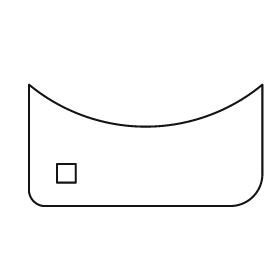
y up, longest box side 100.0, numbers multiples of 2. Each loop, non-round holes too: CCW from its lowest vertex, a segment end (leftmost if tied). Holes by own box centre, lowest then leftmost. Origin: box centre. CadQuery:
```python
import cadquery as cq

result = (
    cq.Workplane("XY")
    .moveTo(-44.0, -26.0)
    .lineTo(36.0, -26.0)
    .threePointArc((46.0, -22.0), (50.0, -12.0))
    .lineTo(50.0, 26.0)
    .threePointArc((0.0, 8.0), (-50.0, 26.0))
    .lineTo(-50.0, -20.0)
    .threePointArc((-48.0, -24.0), (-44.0, -26.0))
    .close()
    .moveTo(-38.0, -16.0)
    .lineTo(-30.0, -16.0)
    .lineTo(-30.0, -8.0)
    .lineTo(-38.0, -8.0)
    .close()
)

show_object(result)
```